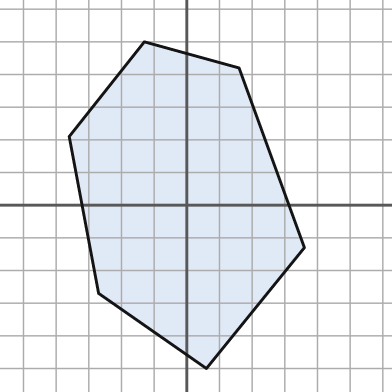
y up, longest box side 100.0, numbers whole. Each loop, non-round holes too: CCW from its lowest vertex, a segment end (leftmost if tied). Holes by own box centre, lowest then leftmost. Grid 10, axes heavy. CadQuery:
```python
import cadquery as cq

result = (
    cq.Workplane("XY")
    .moveTo(6.0, -50.0)
    .lineTo(36.0, -13.0)
    .lineTo(16.0, 42.0)
    .lineTo(-13.0, 50.0)
    .lineTo(-36.0, 21.0)
    .lineTo(-27.0, -27.0)
    .close()
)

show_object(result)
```